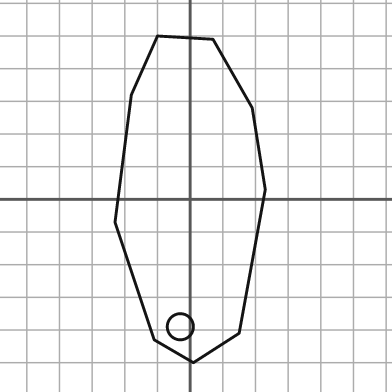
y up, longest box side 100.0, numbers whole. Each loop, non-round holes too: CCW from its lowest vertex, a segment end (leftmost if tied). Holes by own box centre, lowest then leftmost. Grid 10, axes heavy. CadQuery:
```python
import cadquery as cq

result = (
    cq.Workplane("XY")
    .moveTo(1.0, -50.0)
    .lineTo(15.0, -41.0)
    .lineTo(23.0, 3.0)
    .lineTo(19.0, 28.0)
    .lineTo(7.0, 49.0)
    .lineTo(-10.0, 50.0)
    .lineTo(-18.0, 32.0)
    .lineTo(-23.0, -7.0)
    .lineTo(-11.0, -43.0)
    .close()
    .moveTo(-3.0, -39.0)
    .circle(4.0)
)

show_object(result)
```